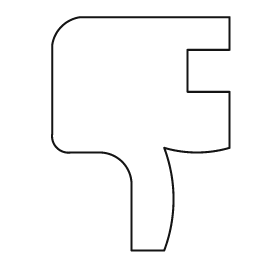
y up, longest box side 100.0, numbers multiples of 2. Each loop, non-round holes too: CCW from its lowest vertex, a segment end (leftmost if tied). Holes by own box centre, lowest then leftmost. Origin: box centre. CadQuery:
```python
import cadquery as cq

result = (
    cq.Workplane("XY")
    .moveTo(-4.0, -50.0)
    .lineTo(10.0, -50.0)
    .threePointArc((14.0, -28.0), (10.0, -6.0))
    .threePointArc((24.0, -8.0), (38.0, -6.0))
    .lineTo(38.0, 18.0)
    .lineTo(20.0, 18.0)
    .lineTo(20.0, 36.0)
    .lineTo(38.0, 36.0)
    .lineTo(38.0, 50.0)
    .lineTo(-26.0, 50.0)
    .threePointArc((-34.0, 46.0), (-38.0, 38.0))
    .lineTo(-38.0, 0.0)
    .threePointArc((-36.0, -6.0), (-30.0, -8.0))
    .lineTo(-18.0, -8.0)
    .threePointArc((-8.0, -12.0), (-4.0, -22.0))
    .close()
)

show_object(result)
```